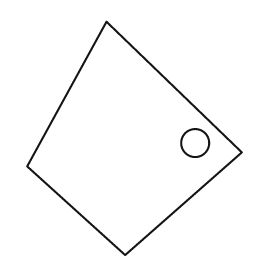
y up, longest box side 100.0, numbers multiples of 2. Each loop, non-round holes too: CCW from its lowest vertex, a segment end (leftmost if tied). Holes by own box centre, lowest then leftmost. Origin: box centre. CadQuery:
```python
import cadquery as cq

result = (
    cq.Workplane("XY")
    .moveTo(-4.0, -50.0)
    .lineTo(46.0, -6.0)
    .lineTo(-12.0, 50.0)
    .lineTo(-46.0, -12.0)
    .close()
    .moveTo(26.0, -2.0)
    .circle(6.0)
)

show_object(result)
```